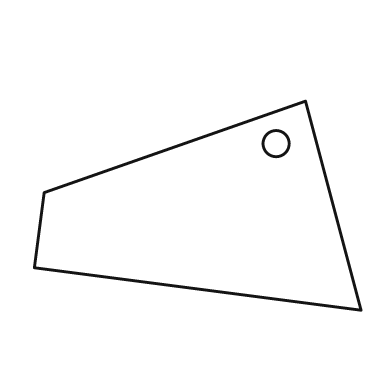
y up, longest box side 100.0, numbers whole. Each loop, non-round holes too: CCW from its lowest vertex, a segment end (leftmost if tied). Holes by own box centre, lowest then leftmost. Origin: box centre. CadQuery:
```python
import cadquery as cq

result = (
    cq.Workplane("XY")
    .moveTo(50.0, -32.0)
    .lineTo(33.0, 32.0)
    .lineTo(-47.0, 4.0)
    .lineTo(-50.0, -19.0)
    .close()
    .moveTo(24.0, 19.0)
    .circle(4.0)
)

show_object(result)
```